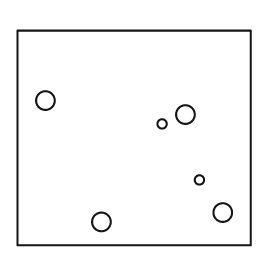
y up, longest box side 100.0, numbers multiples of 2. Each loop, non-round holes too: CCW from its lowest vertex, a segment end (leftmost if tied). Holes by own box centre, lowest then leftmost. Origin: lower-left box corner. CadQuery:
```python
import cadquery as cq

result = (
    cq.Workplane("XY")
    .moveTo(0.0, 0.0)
    .lineTo(100.0, 0.0)
    .lineTo(100.0, 92.0)
    .lineTo(0.0, 92.0)
    .close()
    .moveTo(36.0, 10.0)
    .circle(4.0)
    .moveTo(88.0, 14.0)
    .circle(4.0)
    .moveTo(78.0, 28.0)
    .circle(2.0)
    .moveTo(62.0, 52.0)
    .circle(2.0)
    .moveTo(72.0, 56.0)
    .circle(4.0)
    .moveTo(12.0, 62.0)
    .circle(4.0)
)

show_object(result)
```